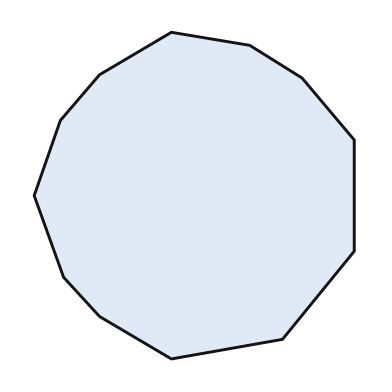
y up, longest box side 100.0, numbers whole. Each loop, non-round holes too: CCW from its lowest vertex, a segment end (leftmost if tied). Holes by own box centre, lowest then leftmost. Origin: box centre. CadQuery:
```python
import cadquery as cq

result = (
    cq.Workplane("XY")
    .moveTo(-7.0, -50.0)
    .lineTo(27.0, -44.0)
    .lineTo(49.0, -17.0)
    .lineTo(49.0, 17.0)
    .lineTo(33.0, 36.0)
    .lineTo(17.0, 46.0)
    .lineTo(-7.0, 50.0)
    .lineTo(-29.0, 37.0)
    .lineTo(-41.0, 23.0)
    .lineTo(-49.0, 0.0)
    .lineTo(-40.0, -25.0)
    .lineTo(-29.0, -37.0)
    .close()
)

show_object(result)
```